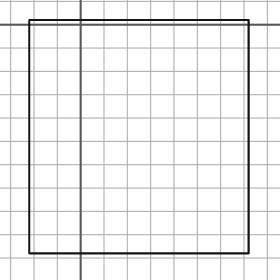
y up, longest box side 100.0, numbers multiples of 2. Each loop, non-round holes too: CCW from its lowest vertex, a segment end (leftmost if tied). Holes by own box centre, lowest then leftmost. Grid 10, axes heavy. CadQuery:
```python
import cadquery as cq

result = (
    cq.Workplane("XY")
    .moveTo(-22.0, -98.0)
    .lineTo(72.0, -98.0)
    .lineTo(72.0, 2.0)
    .lineTo(-22.0, 2.0)
    .close()
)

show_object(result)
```